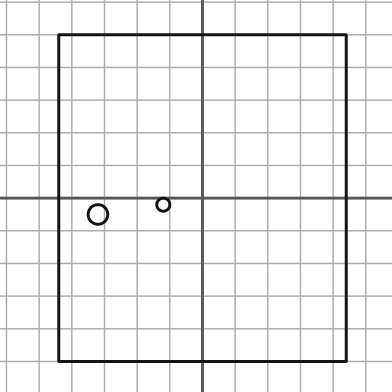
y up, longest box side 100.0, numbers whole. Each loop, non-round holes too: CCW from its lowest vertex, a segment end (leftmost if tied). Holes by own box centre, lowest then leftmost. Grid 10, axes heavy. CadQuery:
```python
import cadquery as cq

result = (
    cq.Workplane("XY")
    .moveTo(-44.0, -50.0)
    .lineTo(44.0, -50.0)
    .lineTo(44.0, 50.0)
    .lineTo(-44.0, 50.0)
    .close()
    .moveTo(-32.0, -5.0)
    .circle(3.0)
    .moveTo(-12.0, -2.0)
    .circle(2.0)
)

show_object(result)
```